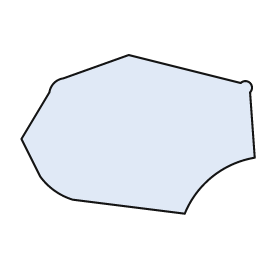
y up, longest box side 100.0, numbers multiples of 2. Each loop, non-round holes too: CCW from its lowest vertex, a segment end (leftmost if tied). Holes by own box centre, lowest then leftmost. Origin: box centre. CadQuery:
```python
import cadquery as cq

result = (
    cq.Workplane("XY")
    .moveTo(20.0, -34.0)
    .threePointArc((32.0, -18.0), (50.0, -10.0))
    .lineTo(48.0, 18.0)
    .threePointArc((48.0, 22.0), (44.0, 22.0))
    .lineTo(-4.0, 34.0)
    .lineTo(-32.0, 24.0)
    .threePointArc((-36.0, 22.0), (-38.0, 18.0))
    .lineTo(-50.0, -2.0)
    .lineTo(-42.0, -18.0)
    .threePointArc((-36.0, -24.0), (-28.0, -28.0))
    .close()
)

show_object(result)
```